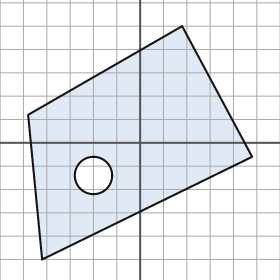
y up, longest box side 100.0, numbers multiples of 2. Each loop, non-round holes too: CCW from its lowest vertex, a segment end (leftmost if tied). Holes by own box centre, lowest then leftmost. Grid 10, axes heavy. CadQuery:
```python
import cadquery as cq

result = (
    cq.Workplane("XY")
    .moveTo(-42.0, -50.0)
    .lineTo(48.0, -6.0)
    .lineTo(18.0, 50.0)
    .lineTo(-48.0, 12.0)
    .close()
    .moveTo(-20.0, -14.0)
    .circle(8.0)
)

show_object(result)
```